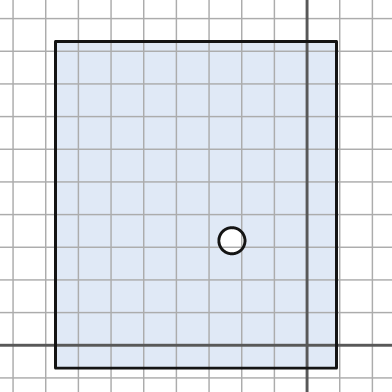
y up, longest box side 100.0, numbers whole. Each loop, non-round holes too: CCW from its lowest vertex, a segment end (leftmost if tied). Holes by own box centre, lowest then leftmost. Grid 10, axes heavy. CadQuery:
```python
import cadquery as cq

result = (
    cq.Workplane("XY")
    .moveTo(-77.0, -7.0)
    .lineTo(9.0, -7.0)
    .lineTo(9.0, 93.0)
    .lineTo(-77.0, 93.0)
    .close()
    .moveTo(-23.0, 32.0)
    .circle(4.0)
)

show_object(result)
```